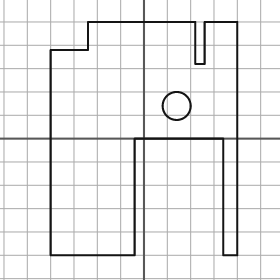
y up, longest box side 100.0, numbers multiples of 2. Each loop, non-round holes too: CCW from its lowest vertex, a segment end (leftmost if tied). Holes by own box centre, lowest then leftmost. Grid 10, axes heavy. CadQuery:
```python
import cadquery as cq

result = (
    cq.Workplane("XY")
    .moveTo(-40.0, -50.0)
    .lineTo(-4.0, -50.0)
    .lineTo(-4.0, 0.0)
    .lineTo(34.0, 0.0)
    .lineTo(34.0, -50.0)
    .lineTo(40.0, -50.0)
    .lineTo(40.0, 50.0)
    .lineTo(26.0, 50.0)
    .lineTo(26.0, 32.0)
    .lineTo(22.0, 32.0)
    .lineTo(22.0, 50.0)
    .lineTo(-24.0, 50.0)
    .lineTo(-24.0, 38.0)
    .lineTo(-40.0, 38.0)
    .close()
    .moveTo(14.0, 14.0)
    .circle(6.0)
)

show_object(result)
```